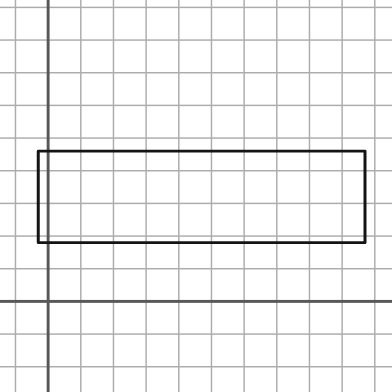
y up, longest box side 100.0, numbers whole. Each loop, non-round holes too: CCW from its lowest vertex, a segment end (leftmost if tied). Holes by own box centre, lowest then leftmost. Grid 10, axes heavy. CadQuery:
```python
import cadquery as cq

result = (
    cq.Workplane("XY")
    .moveTo(-3.0, 18.0)
    .lineTo(97.0, 18.0)
    .lineTo(97.0, 46.0)
    .lineTo(-3.0, 46.0)
    .close()
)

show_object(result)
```